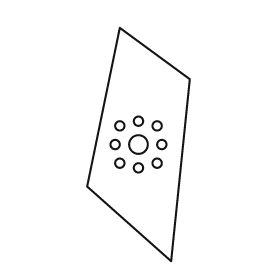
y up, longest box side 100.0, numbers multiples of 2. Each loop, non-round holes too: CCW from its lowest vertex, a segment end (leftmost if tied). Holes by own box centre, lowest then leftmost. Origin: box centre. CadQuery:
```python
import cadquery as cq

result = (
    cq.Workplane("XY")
    .moveTo(14.0, -50.0)
    .lineTo(22.0, 28.0)
    .lineTo(-8.0, 50.0)
    .lineTo(-22.0, -18.0)
    .close()
    .moveTo(0.0, -10.0)
    .circle(2.0)
    .moveTo(-8.0, -8.0)
    .circle(2.0)
    .moveTo(8.0, -8.0)
    .circle(2.0)
    .moveTo(-10.0, 0.0)
    .circle(2.0)
    .moveTo(0.0, 0.0)
    .circle(4.0)
    .moveTo(10.0, 0.0)
    .circle(2.0)
    .moveTo(-8.0, 8.0)
    .circle(2.0)
    .moveTo(8.0, 8.0)
    .circle(2.0)
    .moveTo(0.0, 10.0)
    .circle(2.0)
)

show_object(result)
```